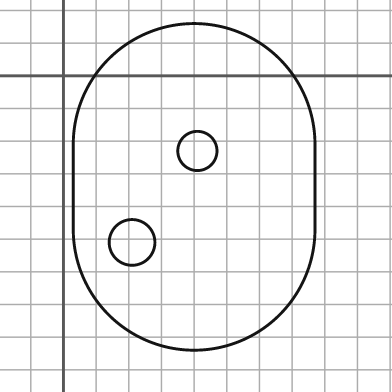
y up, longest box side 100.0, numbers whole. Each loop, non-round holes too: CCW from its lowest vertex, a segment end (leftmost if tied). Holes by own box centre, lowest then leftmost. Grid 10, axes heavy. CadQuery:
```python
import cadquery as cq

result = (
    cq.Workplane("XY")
    .moveTo(3.0, -47.0)
    .threePointArc((40.0, -84.0), (77.0, -47.0))
    .lineTo(77.0, -21.0)
    .threePointArc((40.0, 16.0), (3.0, -21.0))
    .close()
    .moveTo(21.0, -51.0)
    .circle(7.0)
    .moveTo(41.0, -23.0)
    .circle(6.0)
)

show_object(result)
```